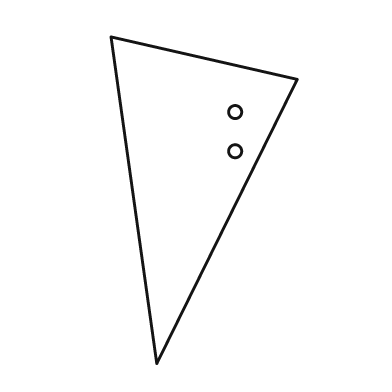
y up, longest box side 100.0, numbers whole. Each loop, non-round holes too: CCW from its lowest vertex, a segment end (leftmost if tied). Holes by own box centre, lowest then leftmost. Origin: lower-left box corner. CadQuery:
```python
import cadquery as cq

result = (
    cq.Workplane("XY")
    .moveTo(14.0, 0.0)
    .lineTo(57.0, 87.0)
    .lineTo(0.0, 100.0)
    .close()
    .moveTo(38.0, 65.0)
    .circle(2.0)
    .moveTo(38.0, 77.0)
    .circle(2.0)
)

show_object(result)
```